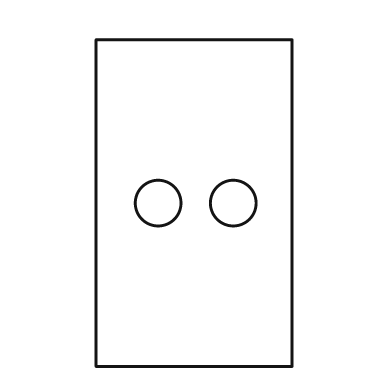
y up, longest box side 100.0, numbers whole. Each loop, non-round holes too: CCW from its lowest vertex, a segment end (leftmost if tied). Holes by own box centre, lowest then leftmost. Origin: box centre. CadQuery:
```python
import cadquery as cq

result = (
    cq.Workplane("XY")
    .moveTo(-30.0, -50.0)
    .lineTo(30.0, -50.0)
    .lineTo(30.0, 50.0)
    .lineTo(-30.0, 50.0)
    .close()
    .moveTo(-11.0, 0.0)
    .circle(7.0)
    .moveTo(12.0, 0.0)
    .circle(7.0)
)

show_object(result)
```